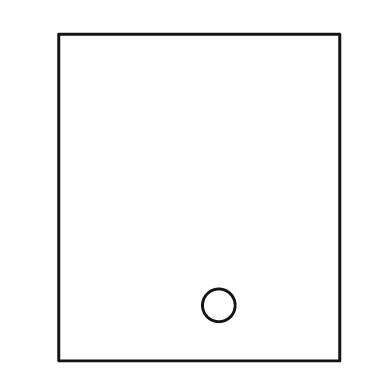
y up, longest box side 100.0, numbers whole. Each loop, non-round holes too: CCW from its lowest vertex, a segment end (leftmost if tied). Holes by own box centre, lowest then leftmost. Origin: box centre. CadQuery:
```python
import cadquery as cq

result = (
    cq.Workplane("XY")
    .moveTo(-43.0, -50.0)
    .lineTo(43.0, -50.0)
    .lineTo(43.0, 50.0)
    .lineTo(-43.0, 50.0)
    .close()
    .moveTo(6.0, -33.0)
    .circle(5.0)
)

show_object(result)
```